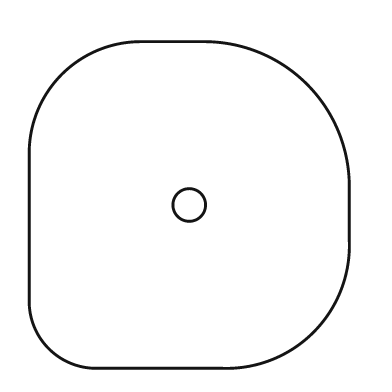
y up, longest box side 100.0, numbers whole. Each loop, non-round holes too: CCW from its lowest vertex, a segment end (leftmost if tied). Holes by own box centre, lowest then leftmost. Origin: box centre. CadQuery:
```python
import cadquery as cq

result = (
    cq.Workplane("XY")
    .moveTo(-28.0, -50.0)
    .lineTo(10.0, -50.0)
    .threePointArc((38.0, -39.0), (49.0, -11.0))
    .lineTo(49.0, 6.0)
    .threePointArc((36.0, 37.0), (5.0, 50.0))
    .lineTo(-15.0, 50.0)
    .threePointArc((-39.0, 40.0), (-49.0, 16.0))
    .lineTo(-49.0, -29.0)
    .threePointArc((-43.0, -44.0), (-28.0, -50.0))
    .close()
    .moveTo(0.0, 0.0)
    .circle(5.0)
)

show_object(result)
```